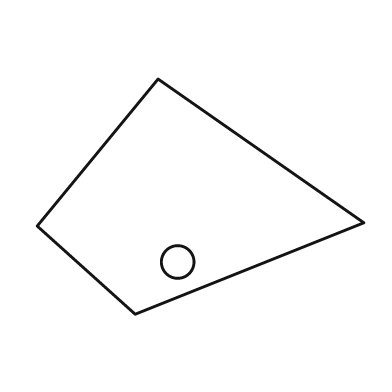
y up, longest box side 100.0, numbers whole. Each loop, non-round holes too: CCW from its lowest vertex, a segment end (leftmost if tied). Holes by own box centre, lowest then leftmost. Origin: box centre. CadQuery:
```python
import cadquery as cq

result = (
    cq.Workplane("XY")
    .moveTo(-20.0, -36.0)
    .lineTo(50.0, -8.0)
    .lineTo(-13.0, 36.0)
    .lineTo(-50.0, -9.0)
    .close()
    .moveTo(-7.0, -20.0)
    .circle(5.0)
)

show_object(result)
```